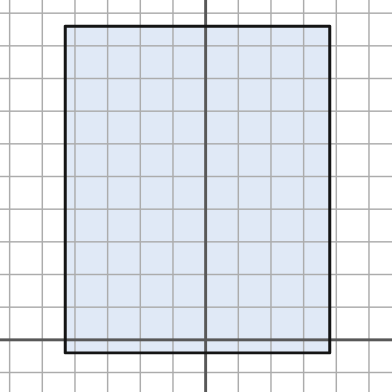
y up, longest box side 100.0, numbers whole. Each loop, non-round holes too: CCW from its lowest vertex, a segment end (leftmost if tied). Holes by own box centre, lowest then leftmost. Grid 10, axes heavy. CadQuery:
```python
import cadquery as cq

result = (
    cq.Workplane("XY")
    .moveTo(-43.0, -4.0)
    .lineTo(38.0, -4.0)
    .lineTo(38.0, 96.0)
    .lineTo(-43.0, 96.0)
    .close()
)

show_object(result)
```